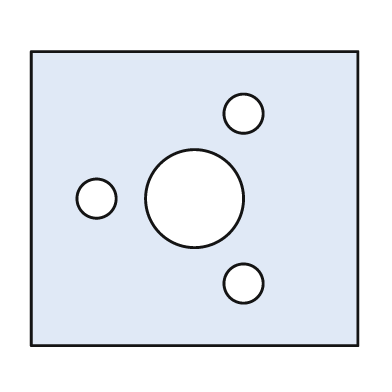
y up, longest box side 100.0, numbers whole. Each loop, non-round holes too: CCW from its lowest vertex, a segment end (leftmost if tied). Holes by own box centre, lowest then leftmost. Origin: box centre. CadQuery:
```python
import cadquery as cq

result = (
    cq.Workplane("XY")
    .moveTo(-50.0, -45.0)
    .lineTo(50.0, -45.0)
    .lineTo(50.0, 45.0)
    .lineTo(-50.0, 45.0)
    .close()
    .moveTo(15.0, -26.0)
    .circle(6.0)
    .moveTo(-30.0, 0.0)
    .circle(6.0)
    .moveTo(0.0, 0.0)
    .circle(15.0)
    .moveTo(15.0, 26.0)
    .circle(6.0)
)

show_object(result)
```